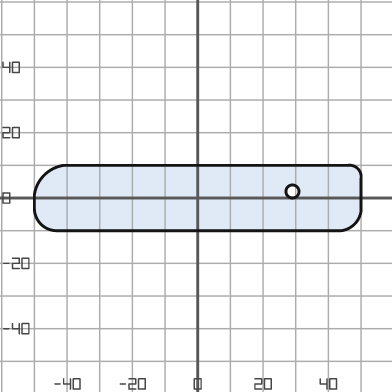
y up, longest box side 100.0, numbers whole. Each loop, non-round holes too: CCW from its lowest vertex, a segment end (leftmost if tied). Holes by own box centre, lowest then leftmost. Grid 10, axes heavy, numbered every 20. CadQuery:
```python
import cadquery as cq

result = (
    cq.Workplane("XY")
    .moveTo(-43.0, -10.0)
    .lineTo(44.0, -10.0)
    .threePointArc((48.0, -8.0), (50.0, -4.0))
    .lineTo(50.0, 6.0)
    .threePointArc((49.0, 9.0), (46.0, 10.0))
    .lineTo(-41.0, 10.0)
    .threePointArc((-47.0, 7.0), (-50.0, 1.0))
    .lineTo(-50.0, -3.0)
    .threePointArc((-48.0, -8.0), (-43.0, -10.0))
    .close()
    .moveTo(29.0, 2.0)
    .circle(2.0)
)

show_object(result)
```